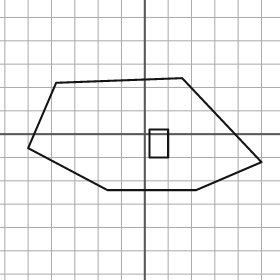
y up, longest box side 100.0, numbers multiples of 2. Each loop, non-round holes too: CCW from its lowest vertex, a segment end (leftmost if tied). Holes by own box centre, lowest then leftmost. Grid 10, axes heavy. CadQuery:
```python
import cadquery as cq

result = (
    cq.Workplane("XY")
    .moveTo(-16.0, -24.0)
    .lineTo(22.0, -24.0)
    .lineTo(50.0, -12.0)
    .lineTo(16.0, 24.0)
    .lineTo(-38.0, 22.0)
    .lineTo(-50.0, -6.0)
    .close()
    .moveTo(2.0, -10.0)
    .lineTo(10.0, -10.0)
    .lineTo(10.0, 2.0)
    .lineTo(2.0, 2.0)
    .close()
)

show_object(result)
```